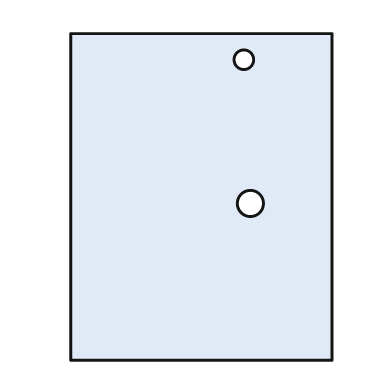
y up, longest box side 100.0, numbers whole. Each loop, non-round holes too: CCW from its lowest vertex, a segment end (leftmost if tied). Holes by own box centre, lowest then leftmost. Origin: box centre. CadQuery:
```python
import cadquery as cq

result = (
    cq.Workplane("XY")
    .moveTo(-40.0, -50.0)
    .lineTo(40.0, -50.0)
    .lineTo(40.0, 50.0)
    .lineTo(-40.0, 50.0)
    .close()
    .moveTo(15.0, -2.0)
    .circle(4.0)
    .moveTo(13.0, 42.0)
    .circle(3.0)
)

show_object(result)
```